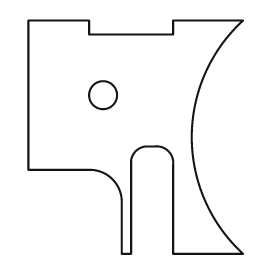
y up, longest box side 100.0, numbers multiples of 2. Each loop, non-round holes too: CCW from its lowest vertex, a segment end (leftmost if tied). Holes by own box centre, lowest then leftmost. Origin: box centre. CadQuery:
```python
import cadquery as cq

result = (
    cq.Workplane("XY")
    .moveTo(-6.0, -50.0)
    .lineTo(-2.0, -50.0)
    .lineTo(-2.0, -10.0)
    .threePointArc((0.0, -6.0), (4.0, -4.0))
    .lineTo(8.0, -4.0)
    .threePointArc((14.0, -6.0), (16.0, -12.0))
    .lineTo(16.0, -50.0)
    .lineTo(46.0, -50.0)
    .threePointArc((24.0, 0.0), (46.0, 50.0))
    .lineTo(16.0, 50.0)
    .lineTo(16.0, 44.0)
    .lineTo(-20.0, 44.0)
    .lineTo(-20.0, 50.0)
    .lineTo(-46.0, 50.0)
    .lineTo(-46.0, -14.0)
    .lineTo(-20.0, -14.0)
    .threePointArc((-10.0, -18.0), (-6.0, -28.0))
    .close()
    .moveTo(-14.0, 18.0)
    .circle(6.0)
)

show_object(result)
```